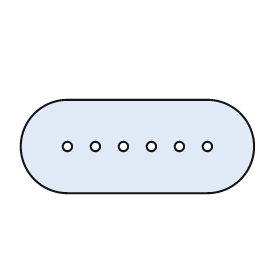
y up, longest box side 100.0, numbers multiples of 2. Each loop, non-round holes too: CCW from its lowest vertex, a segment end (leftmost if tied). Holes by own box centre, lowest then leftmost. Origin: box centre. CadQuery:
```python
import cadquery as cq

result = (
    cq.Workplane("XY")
    .moveTo(-30.0, -20.0)
    .lineTo(30.0, -20.0)
    .threePointArc((50.0, 0.0), (30.0, 20.0))
    .lineTo(-30.0, 20.0)
    .threePointArc((-50.0, 0.0), (-30.0, -20.0))
    .close()
    .moveTo(-30.0, 0.0)
    .circle(2.0)
    .moveTo(-18.0, 0.0)
    .circle(2.0)
    .moveTo(-6.0, 0.0)
    .circle(2.0)
    .moveTo(6.0, 0.0)
    .circle(2.0)
    .moveTo(18.0, 0.0)
    .circle(2.0)
    .moveTo(30.0, 0.0)
    .circle(2.0)
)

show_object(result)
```